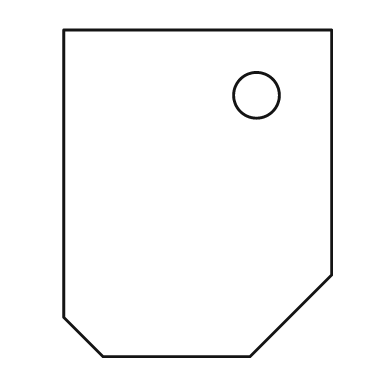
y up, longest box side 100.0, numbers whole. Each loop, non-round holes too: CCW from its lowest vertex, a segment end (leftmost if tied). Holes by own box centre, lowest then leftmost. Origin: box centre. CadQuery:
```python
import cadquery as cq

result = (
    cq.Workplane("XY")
    .moveTo(-29.0, -50.0)
    .lineTo(16.0, -50.0)
    .lineTo(41.0, -25.0)
    .lineTo(41.0, 50.0)
    .lineTo(-41.0, 50.0)
    .lineTo(-41.0, -38.0)
    .close()
    .moveTo(18.0, 30.0)
    .circle(7.0)
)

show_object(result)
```